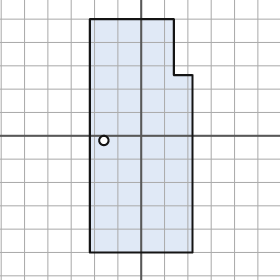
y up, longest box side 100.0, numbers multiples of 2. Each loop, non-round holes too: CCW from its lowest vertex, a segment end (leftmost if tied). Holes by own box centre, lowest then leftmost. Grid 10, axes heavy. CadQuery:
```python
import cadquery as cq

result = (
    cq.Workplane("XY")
    .moveTo(-22.0, -50.0)
    .lineTo(22.0, -50.0)
    .lineTo(22.0, 26.0)
    .lineTo(14.0, 26.0)
    .lineTo(14.0, 50.0)
    .lineTo(-22.0, 50.0)
    .close()
    .moveTo(-16.0, -2.0)
    .circle(2.0)
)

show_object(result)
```